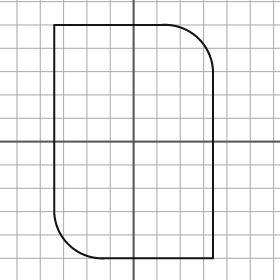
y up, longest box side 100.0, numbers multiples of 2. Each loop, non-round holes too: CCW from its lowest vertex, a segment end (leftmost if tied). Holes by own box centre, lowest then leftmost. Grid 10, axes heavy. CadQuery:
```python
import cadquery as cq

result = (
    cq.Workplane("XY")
    .moveTo(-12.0, -50.0)
    .lineTo(34.0, -50.0)
    .lineTo(34.0, 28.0)
    .threePointArc((28.0, 44.0), (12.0, 50.0))
    .lineTo(-34.0, 50.0)
    .lineTo(-34.0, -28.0)
    .threePointArc((-28.0, -44.0), (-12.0, -50.0))
    .close()
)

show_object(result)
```